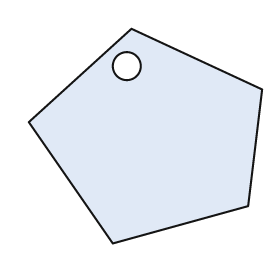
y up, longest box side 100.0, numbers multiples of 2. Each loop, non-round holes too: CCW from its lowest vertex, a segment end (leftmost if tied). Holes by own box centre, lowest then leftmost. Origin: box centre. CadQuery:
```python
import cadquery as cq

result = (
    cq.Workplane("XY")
    .moveTo(-14.0, -46.0)
    .lineTo(44.0, -30.0)
    .lineTo(50.0, 20.0)
    .lineTo(-6.0, 46.0)
    .lineTo(-50.0, 6.0)
    .close()
    .moveTo(-8.0, 30.0)
    .circle(6.0)
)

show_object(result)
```